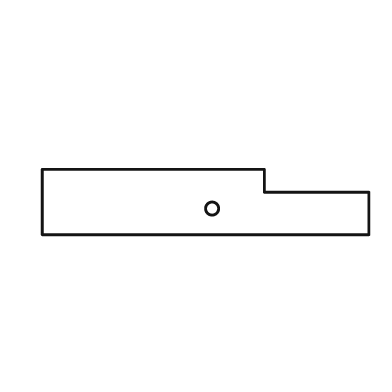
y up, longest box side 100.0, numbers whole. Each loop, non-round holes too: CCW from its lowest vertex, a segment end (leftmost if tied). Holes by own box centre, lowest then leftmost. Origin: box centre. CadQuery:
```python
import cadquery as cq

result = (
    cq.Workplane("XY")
    .moveTo(-50.0, -10.0)
    .lineTo(50.0, -10.0)
    .lineTo(50.0, 3.0)
    .lineTo(18.0, 3.0)
    .lineTo(18.0, 10.0)
    .lineTo(-50.0, 10.0)
    .close()
    .moveTo(2.0, -2.0)
    .circle(2.0)
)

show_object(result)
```